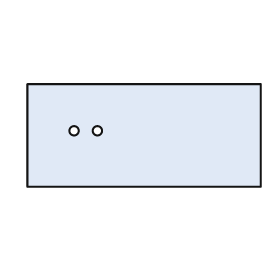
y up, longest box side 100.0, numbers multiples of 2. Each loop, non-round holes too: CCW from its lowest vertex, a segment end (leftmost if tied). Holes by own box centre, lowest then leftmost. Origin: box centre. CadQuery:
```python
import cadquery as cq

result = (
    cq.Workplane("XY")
    .moveTo(-50.0, -22.0)
    .lineTo(50.0, -22.0)
    .lineTo(50.0, 22.0)
    .lineTo(-50.0, 22.0)
    .close()
    .moveTo(-30.0, 2.0)
    .circle(2.0)
    .moveTo(-20.0, 2.0)
    .circle(2.0)
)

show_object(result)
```